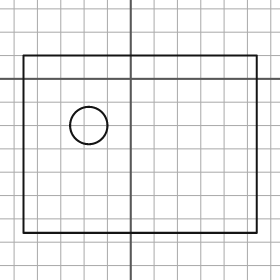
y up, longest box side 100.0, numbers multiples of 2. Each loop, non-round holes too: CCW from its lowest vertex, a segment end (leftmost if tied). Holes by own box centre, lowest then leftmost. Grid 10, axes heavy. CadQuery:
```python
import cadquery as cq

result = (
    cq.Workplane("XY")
    .moveTo(-46.0, -66.0)
    .lineTo(54.0, -66.0)
    .lineTo(54.0, 10.0)
    .lineTo(-46.0, 10.0)
    .close()
    .moveTo(-18.0, -20.0)
    .circle(8.0)
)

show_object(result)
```